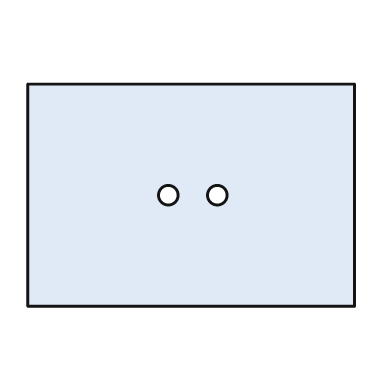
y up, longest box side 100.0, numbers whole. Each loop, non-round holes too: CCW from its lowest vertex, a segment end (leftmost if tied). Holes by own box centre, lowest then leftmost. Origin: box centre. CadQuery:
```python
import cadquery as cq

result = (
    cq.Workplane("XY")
    .moveTo(-50.0, -34.0)
    .lineTo(50.0, -34.0)
    .lineTo(50.0, 34.0)
    .lineTo(-50.0, 34.0)
    .close()
    .moveTo(-7.0, 0.0)
    .circle(3.0)
    .moveTo(8.0, 0.0)
    .circle(3.0)
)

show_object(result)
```